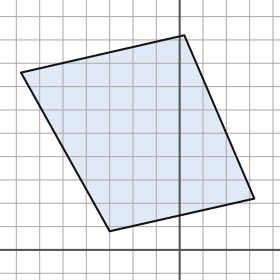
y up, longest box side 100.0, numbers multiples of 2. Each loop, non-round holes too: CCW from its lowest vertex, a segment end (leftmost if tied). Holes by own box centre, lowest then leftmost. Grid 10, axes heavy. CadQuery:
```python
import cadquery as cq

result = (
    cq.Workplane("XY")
    .moveTo(-30.0, 8.0)
    .lineTo(32.0, 22.0)
    .lineTo(2.0, 92.0)
    .lineTo(-68.0, 76.0)
    .close()
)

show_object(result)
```